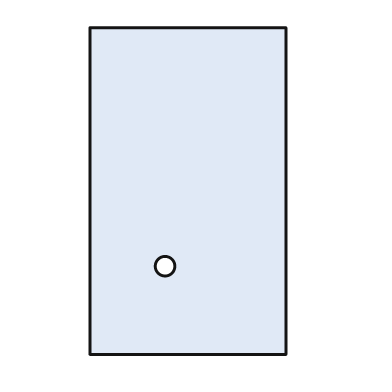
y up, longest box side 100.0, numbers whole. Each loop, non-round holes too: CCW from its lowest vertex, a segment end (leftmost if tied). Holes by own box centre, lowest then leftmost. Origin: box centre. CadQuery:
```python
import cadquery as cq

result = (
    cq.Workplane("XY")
    .moveTo(-30.0, -50.0)
    .lineTo(30.0, -50.0)
    .lineTo(30.0, 50.0)
    .lineTo(-30.0, 50.0)
    .close()
    .moveTo(-7.0, -23.0)
    .circle(3.0)
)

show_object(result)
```